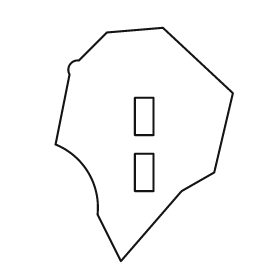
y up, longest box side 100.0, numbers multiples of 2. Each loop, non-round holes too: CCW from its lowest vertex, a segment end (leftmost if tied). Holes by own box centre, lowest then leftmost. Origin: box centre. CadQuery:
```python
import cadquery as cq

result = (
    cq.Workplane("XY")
    .moveTo(-10.0, -50.0)
    .lineTo(16.0, -20.0)
    .lineTo(30.0, -12.0)
    .lineTo(38.0, 22.0)
    .lineTo(8.0, 50.0)
    .lineTo(-16.0, 48.0)
    .lineTo(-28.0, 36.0)
    .threePointArc((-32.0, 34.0), (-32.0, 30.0))
    .lineTo(-38.0, 0.0)
    .threePointArc((-24.0, -12.0), (-20.0, -30.0))
    .close()
    .moveTo(-4.0, -20.0)
    .lineTo(4.0, -20.0)
    .lineTo(4.0, -4.0)
    .lineTo(-4.0, -4.0)
    .close()
    .moveTo(-4.0, 4.0)
    .lineTo(4.0, 4.0)
    .lineTo(4.0, 20.0)
    .lineTo(-4.0, 20.0)
    .close()
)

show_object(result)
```